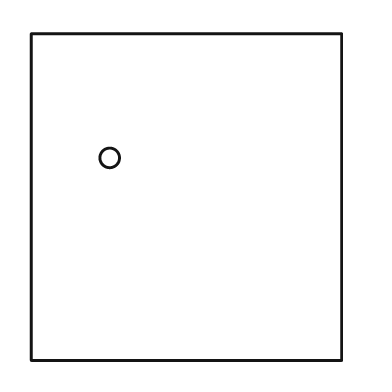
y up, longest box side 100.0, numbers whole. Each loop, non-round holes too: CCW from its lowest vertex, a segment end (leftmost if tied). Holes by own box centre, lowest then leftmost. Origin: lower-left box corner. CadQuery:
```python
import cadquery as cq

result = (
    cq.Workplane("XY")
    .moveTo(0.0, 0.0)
    .lineTo(95.0, 0.0)
    .lineTo(95.0, 100.0)
    .lineTo(0.0, 100.0)
    .close()
    .moveTo(24.0, 62.0)
    .circle(3.0)
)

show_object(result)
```